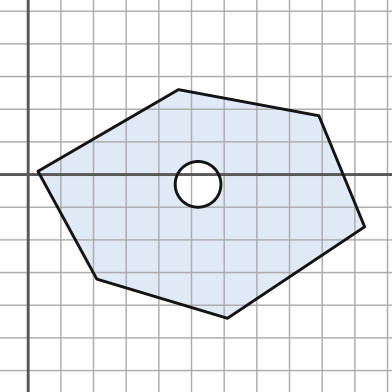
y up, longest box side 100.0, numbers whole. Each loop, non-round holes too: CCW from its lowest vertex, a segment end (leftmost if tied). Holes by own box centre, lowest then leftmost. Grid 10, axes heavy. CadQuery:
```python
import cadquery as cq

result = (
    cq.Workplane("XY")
    .moveTo(61.0, -44.0)
    .lineTo(103.0, -16.0)
    .lineTo(89.0, 18.0)
    .lineTo(46.0, 26.0)
    .lineTo(3.0, 1.0)
    .lineTo(21.0, -32.0)
    .close()
    .moveTo(52.0, -3.0)
    .circle(7.0)
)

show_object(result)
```